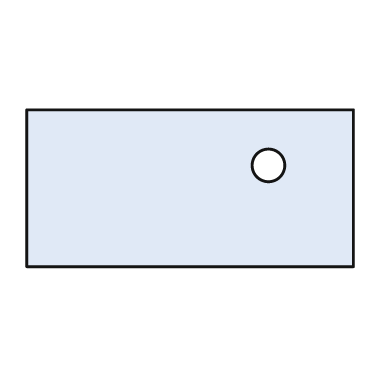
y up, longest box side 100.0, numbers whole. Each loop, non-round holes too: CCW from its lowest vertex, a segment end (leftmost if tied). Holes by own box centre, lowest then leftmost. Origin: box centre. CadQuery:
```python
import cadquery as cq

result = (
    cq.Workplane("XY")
    .moveTo(-50.0, -24.0)
    .lineTo(50.0, -24.0)
    .lineTo(50.0, 24.0)
    .lineTo(-50.0, 24.0)
    .close()
    .moveTo(24.0, 7.0)
    .circle(5.0)
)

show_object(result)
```